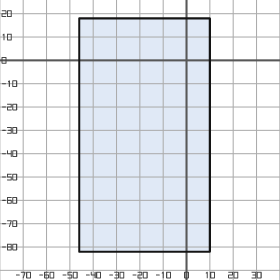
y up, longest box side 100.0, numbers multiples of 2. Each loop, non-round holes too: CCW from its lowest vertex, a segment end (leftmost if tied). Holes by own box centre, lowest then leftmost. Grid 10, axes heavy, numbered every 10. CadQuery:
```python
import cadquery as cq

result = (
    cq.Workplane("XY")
    .moveTo(-46.0, -82.0)
    .lineTo(10.0, -82.0)
    .lineTo(10.0, 18.0)
    .lineTo(-46.0, 18.0)
    .close()
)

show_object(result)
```